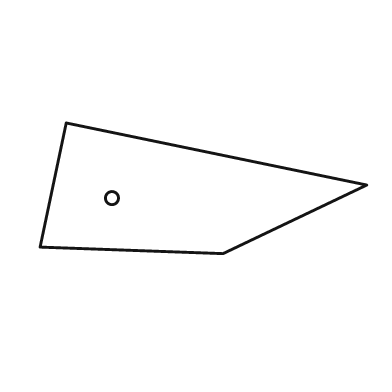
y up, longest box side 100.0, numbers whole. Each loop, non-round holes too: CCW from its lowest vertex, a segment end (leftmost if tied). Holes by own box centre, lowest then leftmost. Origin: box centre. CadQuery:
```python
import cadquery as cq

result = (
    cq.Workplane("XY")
    .moveTo(6.0, -20.0)
    .lineTo(50.0, 1.0)
    .lineTo(-42.0, 20.0)
    .lineTo(-50.0, -18.0)
    .close()
    .moveTo(-28.0, -3.0)
    .circle(2.0)
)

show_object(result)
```